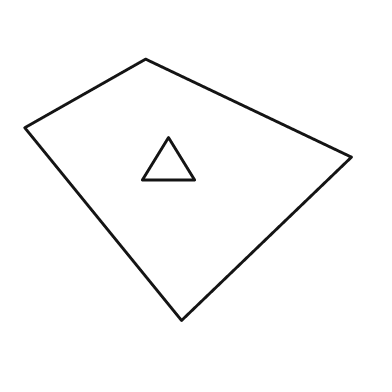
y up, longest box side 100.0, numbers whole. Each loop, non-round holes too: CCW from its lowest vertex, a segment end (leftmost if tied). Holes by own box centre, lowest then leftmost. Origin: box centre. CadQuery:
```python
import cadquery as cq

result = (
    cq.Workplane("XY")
    .moveTo(-2.0, -40.0)
    .lineTo(50.0, 10.0)
    .lineTo(-13.0, 40.0)
    .lineTo(-50.0, 19.0)
    .close()
    .moveTo(-14.0, 3.0)
    .lineTo(2.0, 3.0)
    .lineTo(-6.0, 16.0)
    .close()
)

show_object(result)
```